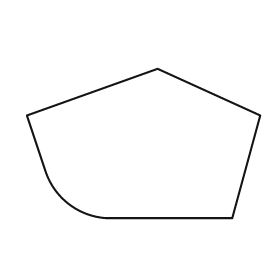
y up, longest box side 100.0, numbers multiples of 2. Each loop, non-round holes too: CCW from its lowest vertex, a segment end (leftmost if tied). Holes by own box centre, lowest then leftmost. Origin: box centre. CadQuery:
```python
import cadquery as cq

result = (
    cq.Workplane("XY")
    .moveTo(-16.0, -32.0)
    .lineTo(38.0, -32.0)
    .lineTo(50.0, 12.0)
    .lineTo(6.0, 32.0)
    .lineTo(-50.0, 12.0)
    .lineTo(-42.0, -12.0)
    .threePointArc((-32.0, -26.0), (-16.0, -32.0))
    .close()
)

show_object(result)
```